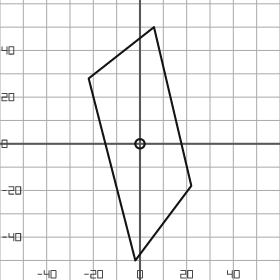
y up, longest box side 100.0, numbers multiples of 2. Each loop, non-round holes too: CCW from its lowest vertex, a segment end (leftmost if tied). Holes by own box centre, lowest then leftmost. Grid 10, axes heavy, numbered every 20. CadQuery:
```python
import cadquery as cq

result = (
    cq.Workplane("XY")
    .moveTo(-2.0, -50.0)
    .lineTo(22.0, -18.0)
    .lineTo(6.0, 50.0)
    .lineTo(-22.0, 28.0)
    .close()
    .moveTo(0.0, 0.0)
    .circle(2.0)
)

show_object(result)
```